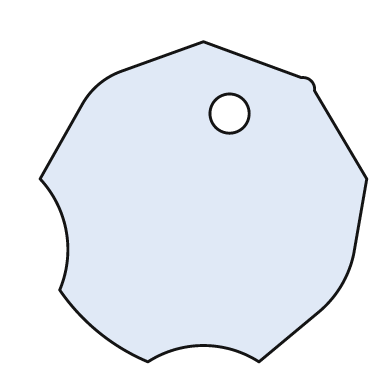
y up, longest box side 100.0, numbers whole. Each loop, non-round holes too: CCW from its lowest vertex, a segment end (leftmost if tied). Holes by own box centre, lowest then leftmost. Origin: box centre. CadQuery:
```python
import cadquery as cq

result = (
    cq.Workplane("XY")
    .moveTo(-17.0, -49.0)
    .threePointArc((0.0, -44.0), (17.0, -49.0))
    .lineTo(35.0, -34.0)
    .threePointArc((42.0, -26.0), (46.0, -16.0))
    .lineTo(50.0, 7.0)
    .lineTo(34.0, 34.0)
    .threePointArc((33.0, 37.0), (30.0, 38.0))
    .lineTo(0.0, 49.0)
    .lineTo(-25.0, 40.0)
    .threePointArc((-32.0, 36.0), (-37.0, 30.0))
    .lineTo(-50.0, 7.0)
    .threePointArc((-42.0, -9.0), (-44.0, -27.0))
    .threePointArc((-32.0, -40.0), (-17.0, -49.0))
    .close()
    .moveTo(8.0, 27.0)
    .circle(6.0)
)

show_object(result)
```